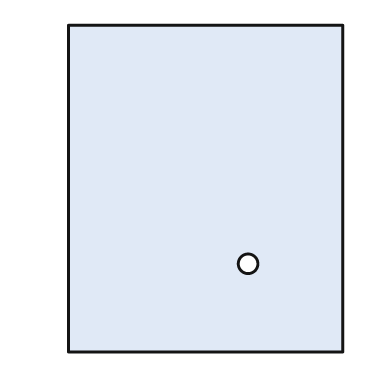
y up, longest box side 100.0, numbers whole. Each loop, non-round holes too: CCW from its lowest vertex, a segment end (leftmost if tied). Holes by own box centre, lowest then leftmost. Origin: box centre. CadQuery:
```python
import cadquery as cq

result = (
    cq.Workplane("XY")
    .moveTo(-42.0, -50.0)
    .lineTo(42.0, -50.0)
    .lineTo(42.0, 50.0)
    .lineTo(-42.0, 50.0)
    .close()
    .moveTo(13.0, -23.0)
    .circle(3.0)
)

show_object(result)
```